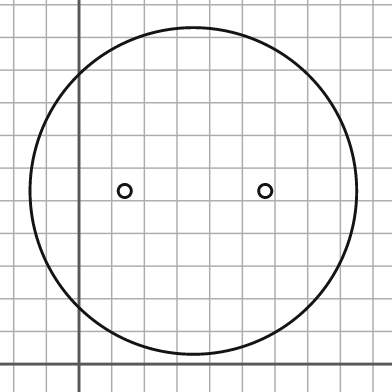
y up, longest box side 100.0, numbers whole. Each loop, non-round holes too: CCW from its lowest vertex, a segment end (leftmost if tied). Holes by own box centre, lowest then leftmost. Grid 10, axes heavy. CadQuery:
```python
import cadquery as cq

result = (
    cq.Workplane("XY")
    .moveTo(35.0, 53.0)
    .circle(50.0)
    .moveTo(14.0, 53.0)
    .circle(2.0)
    .moveTo(57.0, 53.0)
    .circle(2.0)
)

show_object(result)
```